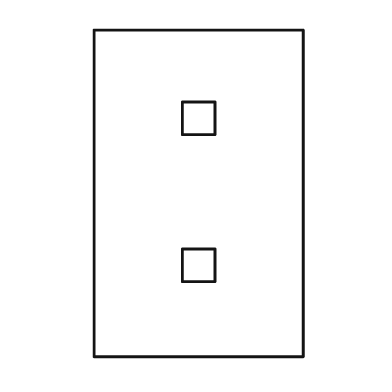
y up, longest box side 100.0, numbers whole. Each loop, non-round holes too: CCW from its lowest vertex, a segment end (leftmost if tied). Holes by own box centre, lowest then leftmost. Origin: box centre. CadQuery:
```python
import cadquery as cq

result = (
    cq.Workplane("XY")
    .moveTo(-32.0, -50.0)
    .lineTo(32.0, -50.0)
    .lineTo(32.0, 50.0)
    .lineTo(-32.0, 50.0)
    .close()
    .moveTo(-5.0, -27.0)
    .lineTo(5.0, -27.0)
    .lineTo(5.0, -17.0)
    .lineTo(-5.0, -17.0)
    .close()
    .moveTo(-5.0, 18.0)
    .lineTo(5.0, 18.0)
    .lineTo(5.0, 28.0)
    .lineTo(-5.0, 28.0)
    .close()
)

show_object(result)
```